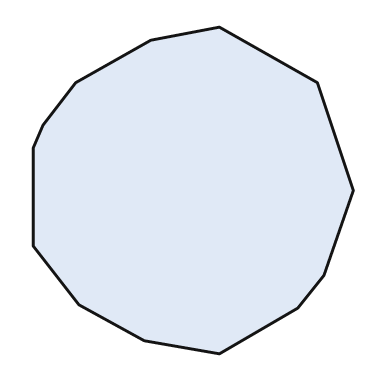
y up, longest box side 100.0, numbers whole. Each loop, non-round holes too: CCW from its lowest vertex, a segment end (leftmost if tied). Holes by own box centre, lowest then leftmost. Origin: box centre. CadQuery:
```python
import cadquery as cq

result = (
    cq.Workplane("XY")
    .moveTo(8.0, -50.0)
    .lineTo(32.0, -36.0)
    .lineTo(40.0, -26.0)
    .lineTo(49.0, 0.0)
    .lineTo(38.0, 33.0)
    .lineTo(8.0, 50.0)
    .lineTo(-13.0, 46.0)
    .lineTo(-36.0, 33.0)
    .lineTo(-46.0, 20.0)
    .lineTo(-49.0, 13.0)
    .lineTo(-49.0, -17.0)
    .lineTo(-35.0, -35.0)
    .lineTo(-15.0, -46.0)
    .close()
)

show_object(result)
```